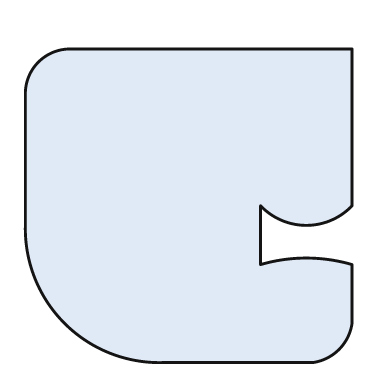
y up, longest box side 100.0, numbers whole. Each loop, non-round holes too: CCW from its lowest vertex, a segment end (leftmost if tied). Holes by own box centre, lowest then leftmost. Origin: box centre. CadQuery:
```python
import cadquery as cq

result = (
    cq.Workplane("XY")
    .moveTo(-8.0, -48.0)
    .lineTo(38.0, -48.0)
    .threePointArc((46.0, -44.0), (50.0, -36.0))
    .lineTo(50.0, -18.0)
    .threePointArc((36.0, -16.0), (22.0, -18.0))
    .lineTo(22.0, 0.0)
    .threePointArc((36.0, -6.0), (50.0, 0.0))
    .lineTo(50.0, 48.0)
    .lineTo(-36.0, 48.0)
    .threePointArc((-46.0, 44.0), (-50.0, 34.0))
    .lineTo(-50.0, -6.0)
    .threePointArc((-38.0, -36.0), (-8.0, -48.0))
    .close()
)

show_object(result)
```